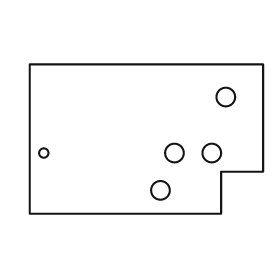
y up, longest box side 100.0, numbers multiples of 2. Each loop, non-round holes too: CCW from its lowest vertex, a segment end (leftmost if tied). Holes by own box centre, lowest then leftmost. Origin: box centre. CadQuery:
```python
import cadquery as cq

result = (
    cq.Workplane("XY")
    .moveTo(-50.0, -32.0)
    .lineTo(32.0, -32.0)
    .lineTo(32.0, -14.0)
    .lineTo(50.0, -14.0)
    .lineTo(50.0, 32.0)
    .lineTo(-50.0, 32.0)
    .close()
    .moveTo(6.0, -22.0)
    .circle(4.0)
    .moveTo(-44.0, -6.0)
    .circle(2.0)
    .moveTo(12.0, -6.0)
    .circle(4.0)
    .moveTo(28.0, -6.0)
    .circle(4.0)
    .moveTo(34.0, 18.0)
    .circle(4.0)
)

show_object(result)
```